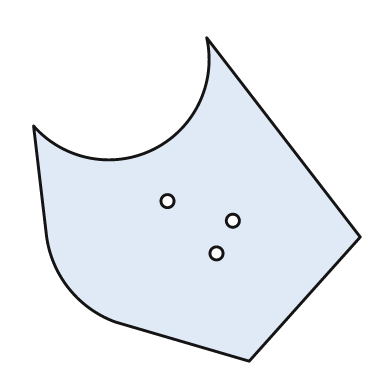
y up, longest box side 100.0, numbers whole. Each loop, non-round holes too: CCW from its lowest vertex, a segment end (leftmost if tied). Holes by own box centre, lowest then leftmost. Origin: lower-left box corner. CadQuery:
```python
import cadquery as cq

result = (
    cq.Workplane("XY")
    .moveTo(66.0, 0.0)
    .lineTo(100.0, 38.0)
    .lineTo(53.0, 99.0)
    .threePointArc((37.0, 65.0), (0.0, 72.0))
    .lineTo(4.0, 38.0)
    .threePointArc((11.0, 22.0), (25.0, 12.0))
    .close()
    .moveTo(56.0, 33.0)
    .circle(2.0)
    .moveTo(61.0, 43.0)
    .circle(2.0)
    .moveTo(41.0, 49.0)
    .circle(2.0)
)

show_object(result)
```